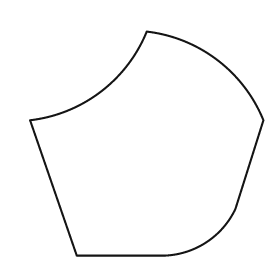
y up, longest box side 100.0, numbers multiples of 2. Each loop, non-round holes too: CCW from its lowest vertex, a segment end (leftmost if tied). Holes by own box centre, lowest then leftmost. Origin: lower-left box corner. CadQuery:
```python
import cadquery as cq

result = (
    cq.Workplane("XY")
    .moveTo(20.0, 0.0)
    .lineTo(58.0, 0.0)
    .threePointArc((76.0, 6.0), (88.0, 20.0))
    .lineTo(100.0, 58.0)
    .threePointArc((80.0, 84.0), (50.0, 96.0))
    .threePointArc((30.0, 70.0), (0.0, 58.0))
    .close()
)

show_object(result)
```